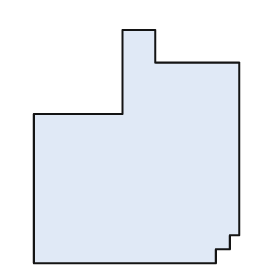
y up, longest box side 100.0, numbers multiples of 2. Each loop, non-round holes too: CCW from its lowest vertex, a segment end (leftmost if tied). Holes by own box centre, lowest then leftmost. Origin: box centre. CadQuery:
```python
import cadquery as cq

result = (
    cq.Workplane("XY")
    .moveTo(-44.0, -50.0)
    .lineTo(34.0, -50.0)
    .lineTo(34.0, -44.0)
    .lineTo(40.0, -44.0)
    .lineTo(40.0, -38.0)
    .lineTo(44.0, -38.0)
    .lineTo(44.0, 36.0)
    .lineTo(8.0, 36.0)
    .lineTo(8.0, 50.0)
    .lineTo(-6.0, 50.0)
    .lineTo(-6.0, 14.0)
    .lineTo(-44.0, 14.0)
    .close()
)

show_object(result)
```